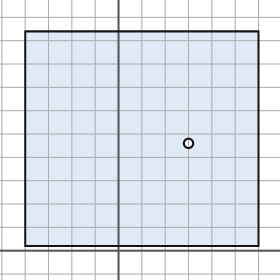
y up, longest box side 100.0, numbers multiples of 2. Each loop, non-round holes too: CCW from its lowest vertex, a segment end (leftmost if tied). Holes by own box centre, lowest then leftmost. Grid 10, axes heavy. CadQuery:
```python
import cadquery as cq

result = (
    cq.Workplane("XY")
    .moveTo(-40.0, 2.0)
    .lineTo(60.0, 2.0)
    .lineTo(60.0, 94.0)
    .lineTo(-40.0, 94.0)
    .close()
    .moveTo(30.0, 46.0)
    .circle(2.0)
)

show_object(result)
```